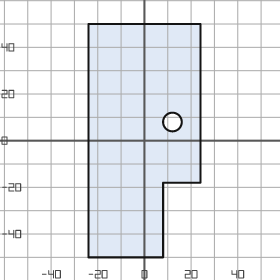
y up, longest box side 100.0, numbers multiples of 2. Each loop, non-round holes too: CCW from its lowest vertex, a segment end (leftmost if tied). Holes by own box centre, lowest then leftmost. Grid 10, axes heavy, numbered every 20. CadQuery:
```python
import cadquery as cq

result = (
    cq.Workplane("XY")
    .moveTo(-24.0, -50.0)
    .lineTo(8.0, -50.0)
    .lineTo(8.0, -18.0)
    .lineTo(24.0, -18.0)
    .lineTo(24.0, 50.0)
    .lineTo(-24.0, 50.0)
    .close()
    .moveTo(12.0, 8.0)
    .circle(4.0)
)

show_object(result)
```